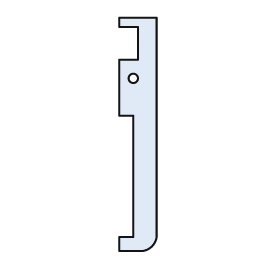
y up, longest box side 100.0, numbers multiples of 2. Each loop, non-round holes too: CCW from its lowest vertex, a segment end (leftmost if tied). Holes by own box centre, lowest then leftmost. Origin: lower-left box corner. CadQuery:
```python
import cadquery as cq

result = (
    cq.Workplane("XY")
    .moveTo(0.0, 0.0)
    .lineTo(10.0, 0.0)
    .threePointArc((14.0, 2.0), (16.0, 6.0))
    .lineTo(16.0, 100.0)
    .lineTo(0.0, 100.0)
    .lineTo(0.0, 96.0)
    .lineTo(8.0, 96.0)
    .lineTo(8.0, 82.0)
    .lineTo(0.0, 82.0)
    .lineTo(0.0, 58.0)
    .lineTo(6.0, 58.0)
    .lineTo(6.0, 6.0)
    .lineTo(0.0, 6.0)
    .close()
    .moveTo(6.0, 74.0)
    .circle(2.0)
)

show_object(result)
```